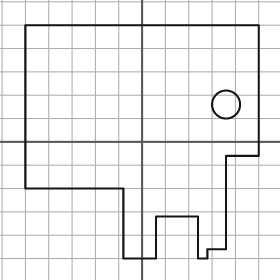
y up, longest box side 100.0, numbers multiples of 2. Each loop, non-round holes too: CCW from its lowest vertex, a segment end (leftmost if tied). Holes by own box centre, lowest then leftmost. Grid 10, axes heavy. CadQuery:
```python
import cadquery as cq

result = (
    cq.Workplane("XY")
    .moveTo(-8.0, -50.0)
    .lineTo(6.0, -50.0)
    .lineTo(6.0, -32.0)
    .lineTo(24.0, -32.0)
    .lineTo(24.0, -50.0)
    .lineTo(28.0, -50.0)
    .lineTo(28.0, -46.0)
    .lineTo(36.0, -46.0)
    .lineTo(36.0, -6.0)
    .lineTo(50.0, -6.0)
    .lineTo(50.0, 50.0)
    .lineTo(-50.0, 50.0)
    .lineTo(-50.0, -20.0)
    .lineTo(-8.0, -20.0)
    .close()
    .moveTo(36.0, 16.0)
    .circle(6.0)
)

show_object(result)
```